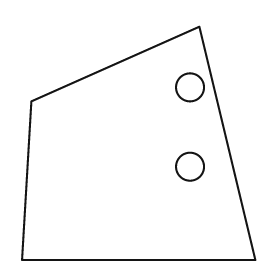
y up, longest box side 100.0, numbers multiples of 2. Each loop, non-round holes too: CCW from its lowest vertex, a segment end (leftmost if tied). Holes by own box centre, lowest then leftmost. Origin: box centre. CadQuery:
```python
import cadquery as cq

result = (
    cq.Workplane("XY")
    .moveTo(-50.0, -50.0)
    .lineTo(50.0, -50.0)
    .lineTo(26.0, 50.0)
    .lineTo(-46.0, 18.0)
    .close()
    .moveTo(22.0, -10.0)
    .circle(6.0)
    .moveTo(22.0, 24.0)
    .circle(6.0)
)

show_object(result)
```